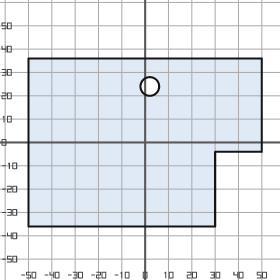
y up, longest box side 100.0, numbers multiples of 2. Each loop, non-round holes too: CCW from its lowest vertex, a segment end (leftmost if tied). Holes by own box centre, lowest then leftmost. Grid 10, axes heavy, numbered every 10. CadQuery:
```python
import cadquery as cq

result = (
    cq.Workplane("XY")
    .moveTo(-50.0, -36.0)
    .lineTo(30.0, -36.0)
    .lineTo(30.0, -4.0)
    .lineTo(50.0, -4.0)
    .lineTo(50.0, 36.0)
    .lineTo(-50.0, 36.0)
    .close()
    .moveTo(2.0, 24.0)
    .circle(4.0)
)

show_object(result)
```